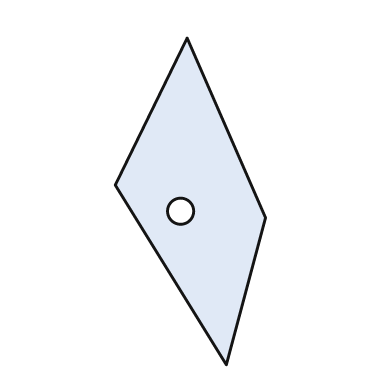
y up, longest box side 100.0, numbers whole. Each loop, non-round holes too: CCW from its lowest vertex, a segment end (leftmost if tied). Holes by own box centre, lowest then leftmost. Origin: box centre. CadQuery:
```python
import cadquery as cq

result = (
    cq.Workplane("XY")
    .moveTo(11.0, -50.0)
    .lineTo(23.0, -5.0)
    .lineTo(-1.0, 50.0)
    .lineTo(-23.0, 5.0)
    .close()
    .moveTo(-3.0, -3.0)
    .circle(4.0)
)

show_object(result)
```